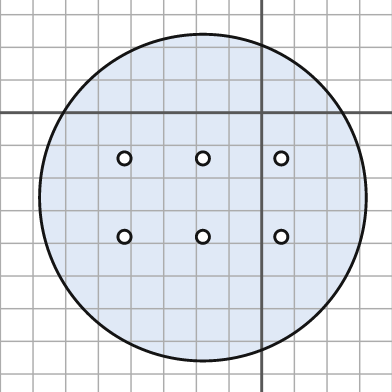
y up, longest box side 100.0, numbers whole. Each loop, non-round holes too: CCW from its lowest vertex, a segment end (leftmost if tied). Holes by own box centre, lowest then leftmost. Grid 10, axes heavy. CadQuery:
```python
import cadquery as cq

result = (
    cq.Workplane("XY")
    .moveTo(-18.0, -26.0)
    .circle(50.0)
    .moveTo(-42.0, -38.0)
    .circle(2.0)
    .moveTo(-18.0, -38.0)
    .circle(2.0)
    .moveTo(6.0, -38.0)
    .circle(2.0)
    .moveTo(-42.0, -14.0)
    .circle(2.0)
    .moveTo(-18.0, -14.0)
    .circle(2.0)
    .moveTo(6.0, -14.0)
    .circle(2.0)
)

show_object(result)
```